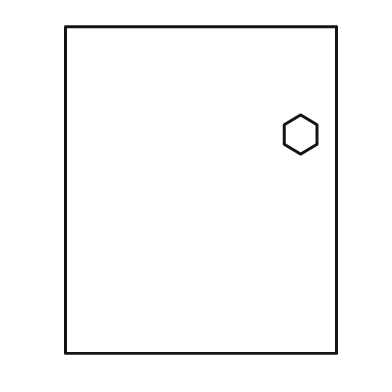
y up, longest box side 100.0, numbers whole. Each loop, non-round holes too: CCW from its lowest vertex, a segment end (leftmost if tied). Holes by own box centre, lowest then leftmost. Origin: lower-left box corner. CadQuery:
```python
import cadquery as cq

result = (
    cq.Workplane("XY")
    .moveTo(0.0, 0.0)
    .lineTo(83.0, 0.0)
    .lineTo(83.0, 100.0)
    .lineTo(0.0, 100.0)
    .close()
    .moveTo(72.0, 61.0)
    .lineTo(77.0, 64.0)
    .lineTo(77.0, 70.0)
    .lineTo(72.0, 73.0)
    .lineTo(67.0, 70.0)
    .lineTo(67.0, 64.0)
    .close()
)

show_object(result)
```